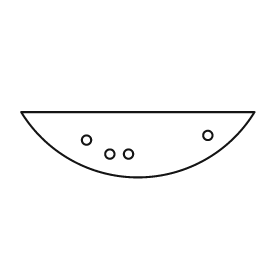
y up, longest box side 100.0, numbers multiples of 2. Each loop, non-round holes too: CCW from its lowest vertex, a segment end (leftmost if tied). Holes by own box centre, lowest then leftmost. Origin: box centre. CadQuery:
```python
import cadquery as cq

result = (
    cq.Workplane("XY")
    .moveTo(-50.0, 14.0)
    .threePointArc((0.0, -14.0), (50.0, 14.0))
    .close()
    .moveTo(-12.0, -4.0)
    .circle(2.0)
    .moveTo(-4.0, -4.0)
    .circle(2.0)
    .moveTo(-22.0, 2.0)
    .circle(2.0)
    .moveTo(30.0, 4.0)
    .circle(2.0)
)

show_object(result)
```